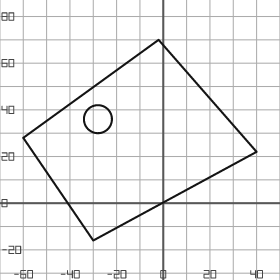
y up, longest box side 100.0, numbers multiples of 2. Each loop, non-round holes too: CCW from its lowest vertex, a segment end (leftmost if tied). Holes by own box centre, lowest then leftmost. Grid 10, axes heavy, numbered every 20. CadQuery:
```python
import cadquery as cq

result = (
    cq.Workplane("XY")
    .moveTo(-30.0, -16.0)
    .lineTo(40.0, 22.0)
    .lineTo(-2.0, 70.0)
    .lineTo(-60.0, 28.0)
    .close()
    .moveTo(-28.0, 36.0)
    .circle(6.0)
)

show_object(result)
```